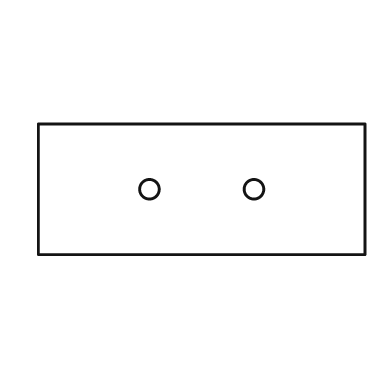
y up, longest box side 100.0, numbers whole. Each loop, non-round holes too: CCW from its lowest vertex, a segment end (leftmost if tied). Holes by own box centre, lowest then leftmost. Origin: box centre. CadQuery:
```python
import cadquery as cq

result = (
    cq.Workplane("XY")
    .moveTo(-50.0, -20.0)
    .lineTo(50.0, -20.0)
    .lineTo(50.0, 20.0)
    .lineTo(-50.0, 20.0)
    .close()
    .moveTo(-16.0, 0.0)
    .circle(3.0)
    .moveTo(16.0, 0.0)
    .circle(3.0)
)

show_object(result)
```